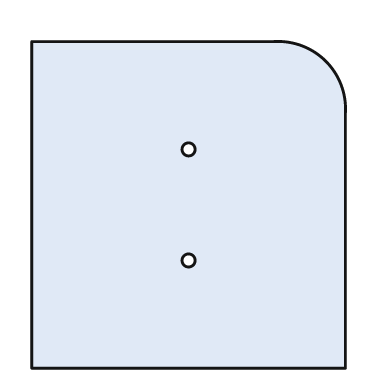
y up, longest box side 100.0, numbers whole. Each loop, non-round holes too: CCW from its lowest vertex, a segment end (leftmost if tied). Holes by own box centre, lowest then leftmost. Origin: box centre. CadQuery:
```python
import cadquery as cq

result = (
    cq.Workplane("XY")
    .moveTo(-48.0, -50.0)
    .lineTo(48.0, -50.0)
    .lineTo(48.0, 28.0)
    .threePointArc((42.0, 44.0), (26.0, 50.0))
    .lineTo(-48.0, 50.0)
    .close()
    .moveTo(0.0, -17.0)
    .circle(2.0)
    .moveTo(0.0, 17.0)
    .circle(2.0)
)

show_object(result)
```